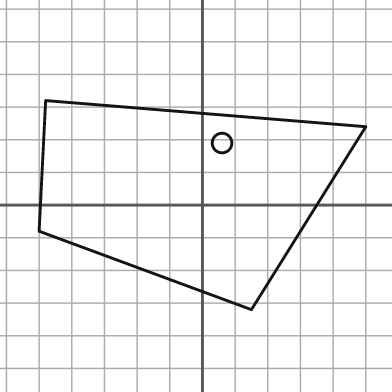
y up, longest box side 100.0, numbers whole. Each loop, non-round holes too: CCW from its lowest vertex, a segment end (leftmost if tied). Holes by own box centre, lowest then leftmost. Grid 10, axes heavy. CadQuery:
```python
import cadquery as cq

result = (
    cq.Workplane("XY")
    .moveTo(15.0, -32.0)
    .lineTo(50.0, 24.0)
    .lineTo(-48.0, 32.0)
    .lineTo(-50.0, -8.0)
    .close()
    .moveTo(6.0, 19.0)
    .circle(3.0)
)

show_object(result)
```